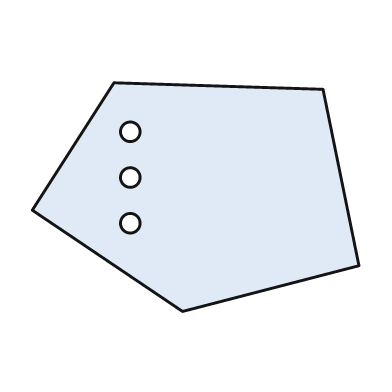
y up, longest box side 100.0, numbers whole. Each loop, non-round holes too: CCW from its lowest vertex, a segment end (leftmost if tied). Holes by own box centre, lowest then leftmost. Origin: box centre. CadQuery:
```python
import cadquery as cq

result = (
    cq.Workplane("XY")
    .moveTo(-4.0, -35.0)
    .lineTo(50.0, -21.0)
    .lineTo(39.0, 33.0)
    .lineTo(-25.0, 35.0)
    .lineTo(-50.0, -4.0)
    .close()
    .moveTo(-20.0, -8.0)
    .circle(3.0)
    .moveTo(-20.0, 6.0)
    .circle(3.0)
    .moveTo(-20.0, 20.0)
    .circle(3.0)
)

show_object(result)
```